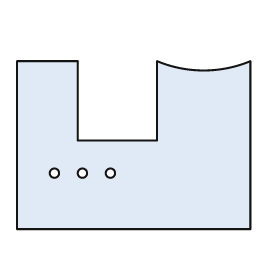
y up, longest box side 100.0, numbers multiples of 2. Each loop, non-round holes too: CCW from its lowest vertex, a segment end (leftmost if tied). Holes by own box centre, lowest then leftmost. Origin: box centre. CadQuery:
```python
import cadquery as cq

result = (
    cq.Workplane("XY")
    .moveTo(-50.0, -36.0)
    .lineTo(50.0, -36.0)
    .lineTo(50.0, 36.0)
    .threePointArc((30.0, 32.0), (10.0, 36.0))
    .lineTo(10.0, 2.0)
    .lineTo(-24.0, 2.0)
    .lineTo(-24.0, 36.0)
    .lineTo(-50.0, 36.0)
    .close()
    .moveTo(-34.0, -12.0)
    .circle(2.0)
    .moveTo(-22.0, -12.0)
    .circle(2.0)
    .moveTo(-10.0, -12.0)
    .circle(2.0)
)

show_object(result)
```